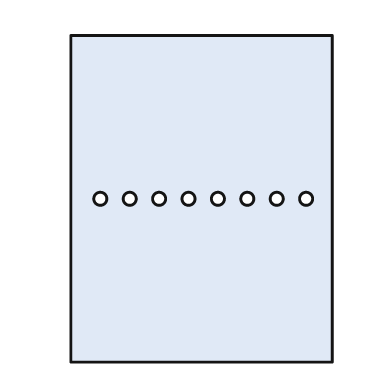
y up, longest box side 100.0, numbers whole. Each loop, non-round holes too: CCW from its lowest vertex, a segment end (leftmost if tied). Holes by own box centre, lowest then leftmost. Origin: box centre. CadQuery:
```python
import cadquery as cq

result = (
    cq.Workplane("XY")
    .moveTo(-40.0, -50.0)
    .lineTo(40.0, -50.0)
    .lineTo(40.0, 50.0)
    .lineTo(-40.0, 50.0)
    .close()
    .moveTo(-31.0, 0.0)
    .circle(2.0)
    .moveTo(-22.0, 0.0)
    .circle(2.0)
    .moveTo(-13.0, 0.0)
    .circle(2.0)
    .moveTo(-4.0, 0.0)
    .circle(2.0)
    .moveTo(5.0, 0.0)
    .circle(2.0)
    .moveTo(14.0, 0.0)
    .circle(2.0)
    .moveTo(23.0, 0.0)
    .circle(2.0)
    .moveTo(32.0, 0.0)
    .circle(2.0)
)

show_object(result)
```